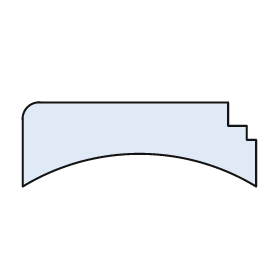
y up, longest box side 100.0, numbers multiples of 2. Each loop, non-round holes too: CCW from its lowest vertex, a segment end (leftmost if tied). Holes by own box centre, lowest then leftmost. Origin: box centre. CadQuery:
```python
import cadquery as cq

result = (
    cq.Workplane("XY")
    .moveTo(-50.0, -18.0)
    .threePointArc((0.0, -4.0), (50.0, -18.0))
    .lineTo(50.0, 2.0)
    .lineTo(46.0, 2.0)
    .lineTo(46.0, 8.0)
    .lineTo(38.0, 8.0)
    .lineTo(38.0, 18.0)
    .lineTo(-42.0, 18.0)
    .threePointArc((-48.0, 16.0), (-50.0, 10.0))
    .close()
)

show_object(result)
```